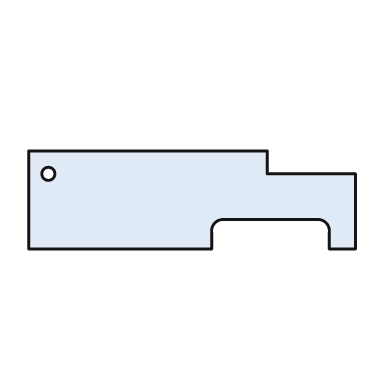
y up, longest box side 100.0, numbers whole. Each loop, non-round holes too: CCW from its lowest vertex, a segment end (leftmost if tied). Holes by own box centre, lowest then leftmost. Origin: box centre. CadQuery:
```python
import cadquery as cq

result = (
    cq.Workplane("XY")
    .moveTo(-50.0, -15.0)
    .lineTo(6.0, -15.0)
    .lineTo(6.0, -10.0)
    .threePointArc((7.0, -7.0), (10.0, -6.0))
    .lineTo(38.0, -6.0)
    .threePointArc((41.0, -7.0), (42.0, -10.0))
    .lineTo(42.0, -15.0)
    .lineTo(50.0, -15.0)
    .lineTo(50.0, 8.0)
    .lineTo(23.0, 8.0)
    .lineTo(23.0, 15.0)
    .lineTo(-50.0, 15.0)
    .close()
    .moveTo(-44.0, 8.0)
    .circle(2.0)
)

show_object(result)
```